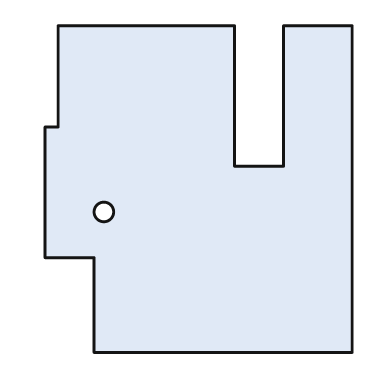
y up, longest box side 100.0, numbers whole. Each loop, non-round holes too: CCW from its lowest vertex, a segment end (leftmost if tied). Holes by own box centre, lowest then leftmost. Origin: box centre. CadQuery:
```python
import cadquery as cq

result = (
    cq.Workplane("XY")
    .moveTo(-32.0, -50.0)
    .lineTo(47.0, -50.0)
    .lineTo(47.0, 50.0)
    .lineTo(26.0, 50.0)
    .lineTo(26.0, 7.0)
    .lineTo(11.0, 7.0)
    .lineTo(11.0, 50.0)
    .lineTo(-43.0, 50.0)
    .lineTo(-43.0, 19.0)
    .lineTo(-47.0, 19.0)
    .lineTo(-47.0, -21.0)
    .lineTo(-32.0, -21.0)
    .close()
    .moveTo(-29.0, -7.0)
    .circle(3.0)
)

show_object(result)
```